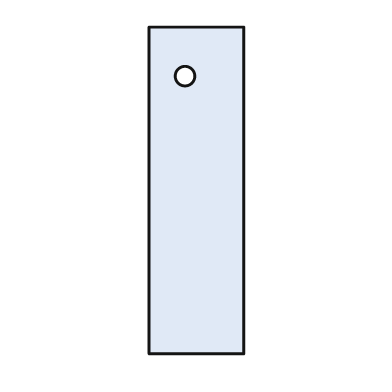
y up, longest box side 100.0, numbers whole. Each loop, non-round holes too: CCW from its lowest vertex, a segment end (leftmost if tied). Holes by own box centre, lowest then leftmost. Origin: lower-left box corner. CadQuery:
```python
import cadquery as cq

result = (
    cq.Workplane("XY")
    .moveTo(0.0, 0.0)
    .lineTo(29.0, 0.0)
    .lineTo(29.0, 100.0)
    .lineTo(0.0, 100.0)
    .close()
    .moveTo(11.0, 85.0)
    .circle(3.0)
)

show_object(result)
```